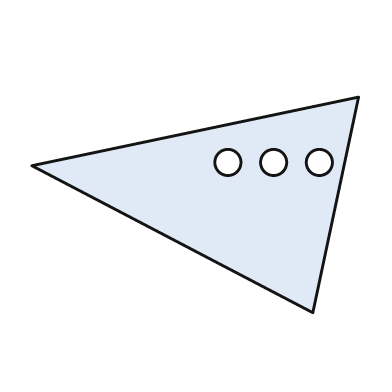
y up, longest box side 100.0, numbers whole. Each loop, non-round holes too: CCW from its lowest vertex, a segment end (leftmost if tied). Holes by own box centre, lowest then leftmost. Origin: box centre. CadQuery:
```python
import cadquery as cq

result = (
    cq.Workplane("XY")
    .moveTo(36.0, -33.0)
    .lineTo(50.0, 33.0)
    .lineTo(-50.0, 12.0)
    .close()
    .moveTo(10.0, 13.0)
    .circle(4.0)
    .moveTo(24.0, 13.0)
    .circle(4.0)
    .moveTo(38.0, 13.0)
    .circle(4.0)
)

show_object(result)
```